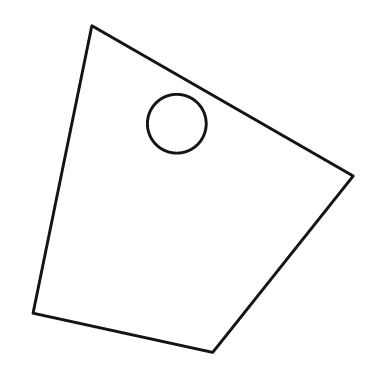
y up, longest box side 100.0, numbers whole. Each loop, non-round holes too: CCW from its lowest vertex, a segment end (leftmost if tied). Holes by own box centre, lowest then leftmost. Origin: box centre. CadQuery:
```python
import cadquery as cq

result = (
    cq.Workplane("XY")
    .moveTo(6.0, -50.0)
    .lineTo(49.0, 4.0)
    .lineTo(-31.0, 50.0)
    .lineTo(-49.0, -38.0)
    .close()
    .moveTo(-5.0, 20.0)
    .circle(9.0)
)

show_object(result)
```